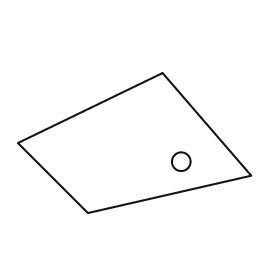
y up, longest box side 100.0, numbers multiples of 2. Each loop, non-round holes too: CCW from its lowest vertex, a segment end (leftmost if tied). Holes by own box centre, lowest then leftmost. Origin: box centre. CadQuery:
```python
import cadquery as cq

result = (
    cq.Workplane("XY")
    .moveTo(-20.0, -30.0)
    .lineTo(50.0, -14.0)
    .lineTo(12.0, 30.0)
    .lineTo(-50.0, 0.0)
    .close()
    .moveTo(20.0, -8.0)
    .circle(4.0)
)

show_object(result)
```